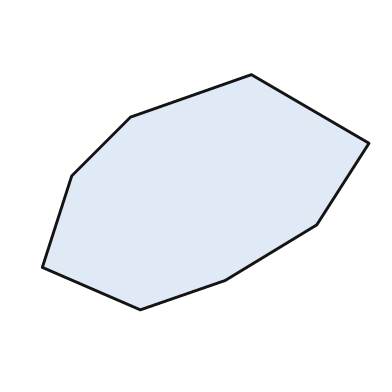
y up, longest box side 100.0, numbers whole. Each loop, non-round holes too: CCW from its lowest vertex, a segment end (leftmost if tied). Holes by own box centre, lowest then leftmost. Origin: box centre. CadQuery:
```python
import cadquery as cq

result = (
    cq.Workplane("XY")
    .moveTo(-20.0, -36.0)
    .lineTo(6.0, -27.0)
    .lineTo(34.0, -10.0)
    .lineTo(50.0, 15.0)
    .lineTo(14.0, 36.0)
    .lineTo(-23.0, 23.0)
    .lineTo(-41.0, 5.0)
    .lineTo(-50.0, -23.0)
    .close()
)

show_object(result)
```